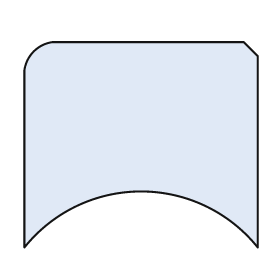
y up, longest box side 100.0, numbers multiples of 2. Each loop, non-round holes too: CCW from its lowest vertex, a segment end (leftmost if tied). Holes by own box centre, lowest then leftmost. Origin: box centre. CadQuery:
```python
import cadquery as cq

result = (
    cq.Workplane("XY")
    .moveTo(-50.0, -44.0)
    .threePointArc((0.0, -20.0), (50.0, -44.0))
    .lineTo(50.0, 38.0)
    .lineTo(44.0, 44.0)
    .lineTo(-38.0, 44.0)
    .threePointArc((-46.0, 40.0), (-50.0, 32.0))
    .close()
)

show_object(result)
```